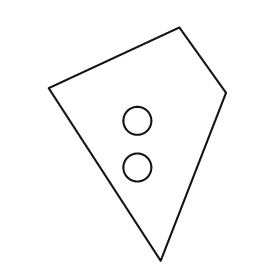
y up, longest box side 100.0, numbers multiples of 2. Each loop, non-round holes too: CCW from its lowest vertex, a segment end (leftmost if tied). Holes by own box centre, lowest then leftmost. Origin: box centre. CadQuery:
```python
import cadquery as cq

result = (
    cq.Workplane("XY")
    .moveTo(10.0, -50.0)
    .lineTo(38.0, 22.0)
    .lineTo(18.0, 50.0)
    .lineTo(-38.0, 24.0)
    .close()
    .moveTo(0.0, -10.0)
    .circle(6.0)
    .moveTo(0.0, 10.0)
    .circle(6.0)
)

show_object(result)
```